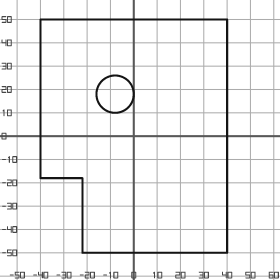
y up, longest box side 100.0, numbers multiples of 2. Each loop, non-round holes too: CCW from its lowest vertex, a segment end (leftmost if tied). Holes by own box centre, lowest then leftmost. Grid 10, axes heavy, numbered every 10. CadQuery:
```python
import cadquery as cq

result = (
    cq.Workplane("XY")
    .moveTo(-22.0, -50.0)
    .lineTo(40.0, -50.0)
    .lineTo(40.0, 50.0)
    .lineTo(-40.0, 50.0)
    .lineTo(-40.0, -18.0)
    .lineTo(-22.0, -18.0)
    .close()
    .moveTo(-8.0, 18.0)
    .circle(8.0)
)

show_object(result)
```